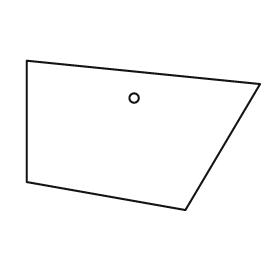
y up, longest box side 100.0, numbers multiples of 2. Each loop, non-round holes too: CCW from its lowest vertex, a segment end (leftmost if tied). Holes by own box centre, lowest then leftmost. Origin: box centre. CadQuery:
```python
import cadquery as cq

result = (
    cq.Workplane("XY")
    .moveTo(18.0, -32.0)
    .lineTo(50.0, 22.0)
    .lineTo(-50.0, 32.0)
    .lineTo(-50.0, -20.0)
    .close()
    .moveTo(-4.0, 16.0)
    .circle(2.0)
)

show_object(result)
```